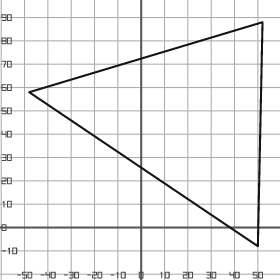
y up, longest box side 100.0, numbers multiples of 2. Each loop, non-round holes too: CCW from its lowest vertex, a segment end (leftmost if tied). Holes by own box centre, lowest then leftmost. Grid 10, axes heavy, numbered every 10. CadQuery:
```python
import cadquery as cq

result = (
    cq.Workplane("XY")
    .moveTo(50.0, -8.0)
    .lineTo(52.0, 88.0)
    .lineTo(-48.0, 58.0)
    .close()
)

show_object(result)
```